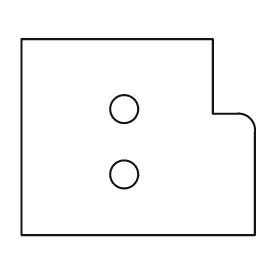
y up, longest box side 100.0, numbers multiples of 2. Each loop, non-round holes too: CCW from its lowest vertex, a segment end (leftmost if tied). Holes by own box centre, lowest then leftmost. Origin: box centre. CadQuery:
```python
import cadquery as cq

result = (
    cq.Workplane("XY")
    .moveTo(-50.0, -42.0)
    .lineTo(50.0, -42.0)
    .lineTo(50.0, 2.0)
    .threePointArc((48.0, 8.0), (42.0, 10.0))
    .lineTo(32.0, 10.0)
    .lineTo(32.0, 42.0)
    .lineTo(-50.0, 42.0)
    .close()
    .moveTo(-6.0, -16.0)
    .circle(6.0)
    .moveTo(-6.0, 12.0)
    .circle(6.0)
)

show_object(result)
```